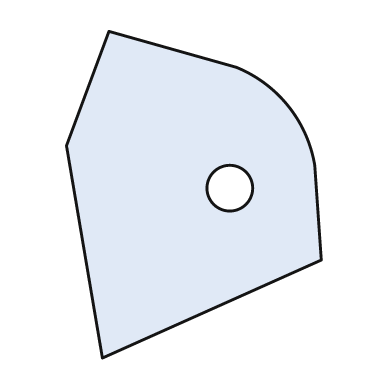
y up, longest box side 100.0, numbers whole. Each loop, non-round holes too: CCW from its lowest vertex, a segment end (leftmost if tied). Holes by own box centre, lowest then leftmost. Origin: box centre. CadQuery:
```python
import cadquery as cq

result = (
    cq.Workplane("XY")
    .moveTo(-28.0, -50.0)
    .lineTo(39.0, -20.0)
    .lineTo(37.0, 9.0)
    .threePointArc((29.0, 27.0), (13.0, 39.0))
    .lineTo(-26.0, 50.0)
    .lineTo(-39.0, 15.0)
    .close()
    .moveTo(11.0, 2.0)
    .circle(7.0)
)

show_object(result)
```